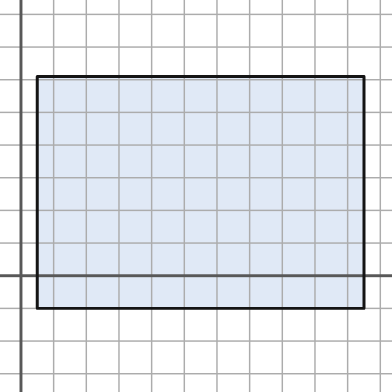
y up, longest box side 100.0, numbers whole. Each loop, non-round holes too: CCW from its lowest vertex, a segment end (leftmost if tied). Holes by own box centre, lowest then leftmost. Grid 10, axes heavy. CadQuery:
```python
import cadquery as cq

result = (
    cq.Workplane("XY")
    .moveTo(5.0, -10.0)
    .lineTo(105.0, -10.0)
    .lineTo(105.0, 61.0)
    .lineTo(5.0, 61.0)
    .close()
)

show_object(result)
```